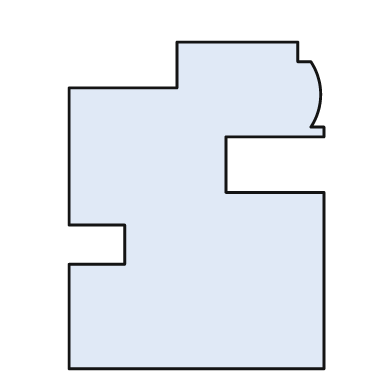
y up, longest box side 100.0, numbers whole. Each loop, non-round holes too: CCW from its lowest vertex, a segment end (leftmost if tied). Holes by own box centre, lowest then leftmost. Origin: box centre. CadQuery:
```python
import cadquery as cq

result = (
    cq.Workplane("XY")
    .moveTo(-39.0, -50.0)
    .lineTo(39.0, -50.0)
    .lineTo(39.0, 4.0)
    .lineTo(9.0, 4.0)
    .lineTo(9.0, 21.0)
    .lineTo(39.0, 21.0)
    .lineTo(39.0, 24.0)
    .lineTo(35.0, 24.0)
    .threePointArc((38.0, 34.0), (35.0, 44.0))
    .lineTo(31.0, 44.0)
    .lineTo(31.0, 50.0)
    .lineTo(-6.0, 50.0)
    .lineTo(-6.0, 36.0)
    .lineTo(-39.0, 36.0)
    .lineTo(-39.0, -6.0)
    .lineTo(-22.0, -6.0)
    .lineTo(-22.0, -18.0)
    .lineTo(-39.0, -18.0)
    .close()
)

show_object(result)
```